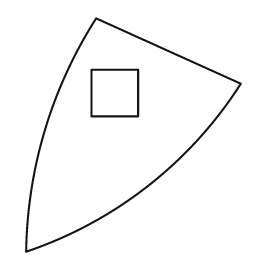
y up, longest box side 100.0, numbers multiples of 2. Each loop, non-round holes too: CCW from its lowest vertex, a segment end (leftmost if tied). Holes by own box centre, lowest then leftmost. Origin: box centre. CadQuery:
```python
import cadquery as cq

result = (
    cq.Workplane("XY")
    .moveTo(-46.0, -50.0)
    .threePointArc((6.0, -22.0), (46.0, 22.0))
    .lineTo(-16.0, 50.0)
    .threePointArc((-38.0, 2.0), (-46.0, -50.0))
    .close()
    .moveTo(-18.0, 8.0)
    .lineTo(2.0, 8.0)
    .lineTo(2.0, 28.0)
    .lineTo(-18.0, 28.0)
    .close()
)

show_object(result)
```